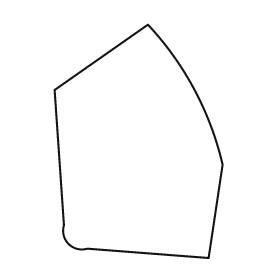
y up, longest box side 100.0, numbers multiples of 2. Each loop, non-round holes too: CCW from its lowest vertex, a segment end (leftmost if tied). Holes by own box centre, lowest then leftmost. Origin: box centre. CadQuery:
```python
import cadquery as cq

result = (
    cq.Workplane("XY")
    .moveTo(30.0, -50.0)
    .lineTo(36.0, -10.0)
    .threePointArc((24.0, 22.0), (4.0, 50.0))
    .lineTo(-36.0, 22.0)
    .lineTo(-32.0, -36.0)
    .threePointArc((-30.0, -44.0), (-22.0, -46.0))
    .close()
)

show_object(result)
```